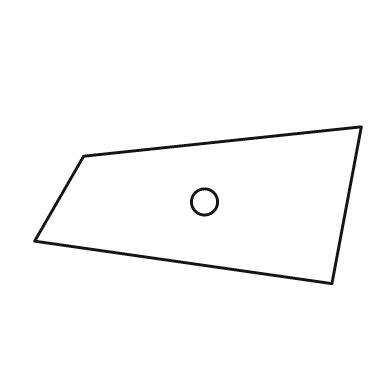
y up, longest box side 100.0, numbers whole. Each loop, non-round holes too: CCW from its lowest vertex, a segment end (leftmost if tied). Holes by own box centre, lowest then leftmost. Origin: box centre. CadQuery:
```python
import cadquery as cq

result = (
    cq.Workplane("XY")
    .moveTo(41.0, -24.0)
    .lineTo(50.0, 24.0)
    .lineTo(-35.0, 15.0)
    .lineTo(-50.0, -11.0)
    .close()
    .moveTo(2.0, 1.0)
    .circle(4.0)
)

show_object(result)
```